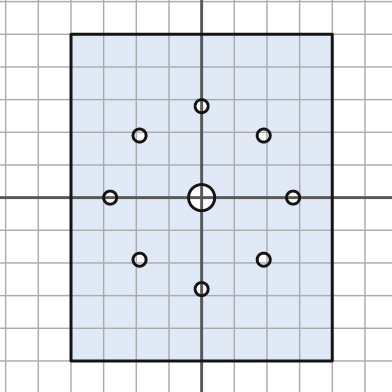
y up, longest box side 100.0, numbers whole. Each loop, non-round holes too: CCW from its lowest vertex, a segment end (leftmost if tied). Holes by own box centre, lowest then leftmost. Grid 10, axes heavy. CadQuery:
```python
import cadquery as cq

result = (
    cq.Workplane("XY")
    .moveTo(-40.0, -50.0)
    .lineTo(40.0, -50.0)
    .lineTo(40.0, 50.0)
    .lineTo(-40.0, 50.0)
    .close()
    .moveTo(0.0, -28.0)
    .circle(2.0)
    .moveTo(-19.0, -19.0)
    .circle(2.0)
    .moveTo(19.0, -19.0)
    .circle(2.0)
    .moveTo(-28.0, 0.0)
    .circle(2.0)
    .moveTo(0.0, 0.0)
    .circle(4.0)
    .moveTo(28.0, 0.0)
    .circle(2.0)
    .moveTo(-19.0, 19.0)
    .circle(2.0)
    .moveTo(19.0, 19.0)
    .circle(2.0)
    .moveTo(0.0, 28.0)
    .circle(2.0)
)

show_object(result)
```